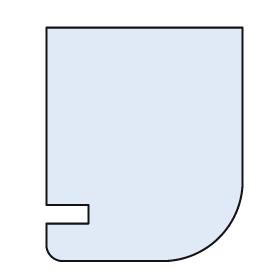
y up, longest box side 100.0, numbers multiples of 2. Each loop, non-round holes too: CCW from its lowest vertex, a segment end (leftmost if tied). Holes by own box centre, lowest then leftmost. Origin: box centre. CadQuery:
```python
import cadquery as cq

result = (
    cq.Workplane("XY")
    .moveTo(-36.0, -50.0)
    .lineTo(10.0, -50.0)
    .threePointArc((32.0, -40.0), (42.0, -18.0))
    .lineTo(42.0, 50.0)
    .lineTo(-42.0, 50.0)
    .lineTo(-42.0, -26.0)
    .lineTo(-24.0, -26.0)
    .lineTo(-24.0, -34.0)
    .lineTo(-42.0, -34.0)
    .lineTo(-42.0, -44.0)
    .threePointArc((-40.0, -48.0), (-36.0, -50.0))
    .close()
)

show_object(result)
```